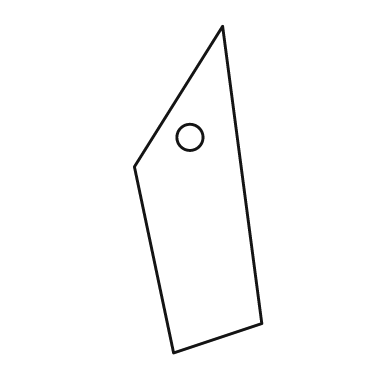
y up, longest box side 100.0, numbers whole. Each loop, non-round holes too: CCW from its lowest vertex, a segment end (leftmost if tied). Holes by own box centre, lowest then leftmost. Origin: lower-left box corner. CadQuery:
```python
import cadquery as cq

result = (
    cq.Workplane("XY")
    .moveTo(12.0, 0.0)
    .lineTo(39.0, 9.0)
    .lineTo(27.0, 100.0)
    .lineTo(0.0, 57.0)
    .close()
    .moveTo(17.0, 66.0)
    .circle(4.0)
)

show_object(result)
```